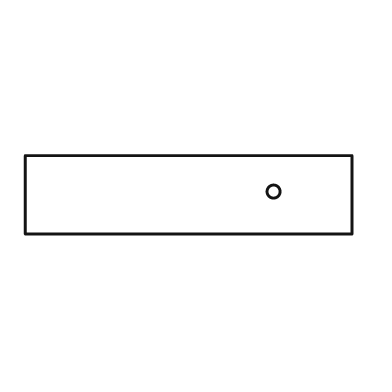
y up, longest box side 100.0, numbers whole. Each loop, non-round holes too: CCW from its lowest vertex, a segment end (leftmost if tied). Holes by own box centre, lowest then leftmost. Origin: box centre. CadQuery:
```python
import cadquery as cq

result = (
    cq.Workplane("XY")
    .moveTo(-50.0, -12.0)
    .lineTo(50.0, -12.0)
    .lineTo(50.0, 12.0)
    .lineTo(-50.0, 12.0)
    .close()
    .moveTo(26.0, 1.0)
    .circle(2.0)
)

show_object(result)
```